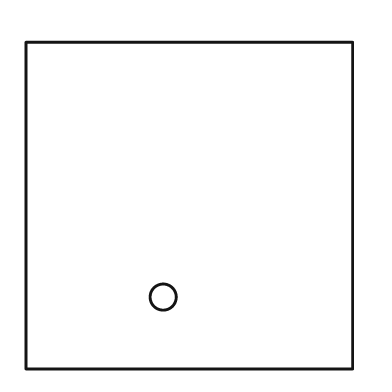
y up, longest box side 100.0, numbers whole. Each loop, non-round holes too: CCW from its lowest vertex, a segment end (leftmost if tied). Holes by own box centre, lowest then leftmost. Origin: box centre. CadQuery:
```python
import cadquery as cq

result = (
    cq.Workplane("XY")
    .moveTo(-50.0, -50.0)
    .lineTo(50.0, -50.0)
    .lineTo(50.0, 50.0)
    .lineTo(-50.0, 50.0)
    .close()
    .moveTo(-8.0, -28.0)
    .circle(4.0)
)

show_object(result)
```